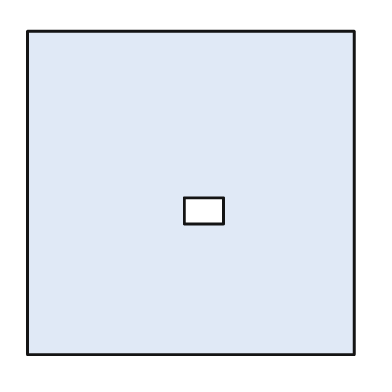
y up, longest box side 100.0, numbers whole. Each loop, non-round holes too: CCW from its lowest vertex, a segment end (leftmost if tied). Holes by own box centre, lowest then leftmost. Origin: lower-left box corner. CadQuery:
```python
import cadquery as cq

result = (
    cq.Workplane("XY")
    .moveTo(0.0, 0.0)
    .lineTo(100.0, 0.0)
    .lineTo(100.0, 99.0)
    .lineTo(0.0, 99.0)
    .close()
    .moveTo(48.0, 40.0)
    .lineTo(60.0, 40.0)
    .lineTo(60.0, 48.0)
    .lineTo(48.0, 48.0)
    .close()
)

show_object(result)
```